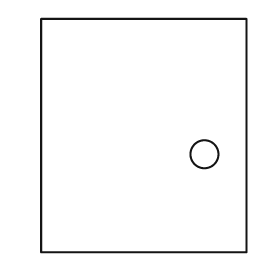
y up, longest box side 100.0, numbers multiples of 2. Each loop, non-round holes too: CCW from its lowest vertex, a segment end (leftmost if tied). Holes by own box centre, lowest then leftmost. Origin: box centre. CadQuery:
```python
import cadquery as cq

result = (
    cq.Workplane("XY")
    .moveTo(-44.0, -50.0)
    .lineTo(44.0, -50.0)
    .lineTo(44.0, 50.0)
    .lineTo(-44.0, 50.0)
    .close()
    .moveTo(26.0, -8.0)
    .circle(6.0)
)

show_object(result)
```